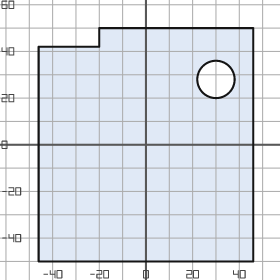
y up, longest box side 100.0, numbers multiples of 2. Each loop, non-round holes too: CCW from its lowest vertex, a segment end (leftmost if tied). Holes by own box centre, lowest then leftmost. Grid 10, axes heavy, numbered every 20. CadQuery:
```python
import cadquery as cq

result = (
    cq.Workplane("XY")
    .moveTo(-46.0, -50.0)
    .lineTo(46.0, -50.0)
    .lineTo(46.0, 50.0)
    .lineTo(-20.0, 50.0)
    .lineTo(-20.0, 42.0)
    .lineTo(-46.0, 42.0)
    .close()
    .moveTo(30.0, 28.0)
    .circle(8.0)
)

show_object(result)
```